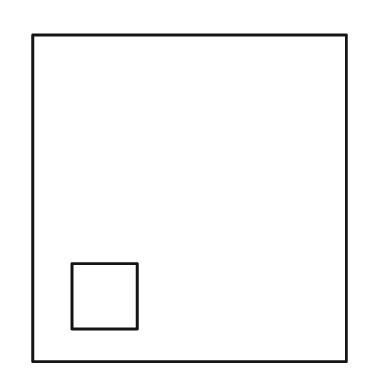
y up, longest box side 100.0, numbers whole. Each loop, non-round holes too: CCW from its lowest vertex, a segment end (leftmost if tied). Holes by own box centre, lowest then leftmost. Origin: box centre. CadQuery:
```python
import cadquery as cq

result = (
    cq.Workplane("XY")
    .moveTo(-48.0, -50.0)
    .lineTo(48.0, -50.0)
    .lineTo(48.0, 50.0)
    .lineTo(-48.0, 50.0)
    .close()
    .moveTo(-36.0, -40.0)
    .lineTo(-16.0, -40.0)
    .lineTo(-16.0, -20.0)
    .lineTo(-36.0, -20.0)
    .close()
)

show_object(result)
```